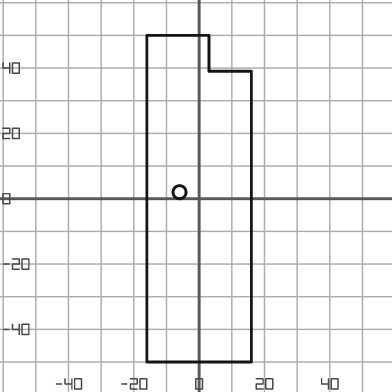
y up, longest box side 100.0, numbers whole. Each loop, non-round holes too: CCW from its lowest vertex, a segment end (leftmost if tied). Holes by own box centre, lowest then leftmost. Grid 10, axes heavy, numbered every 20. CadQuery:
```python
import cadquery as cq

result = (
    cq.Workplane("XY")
    .moveTo(-16.0, -50.0)
    .lineTo(16.0, -50.0)
    .lineTo(16.0, 39.0)
    .lineTo(3.0, 39.0)
    .lineTo(3.0, 50.0)
    .lineTo(-16.0, 50.0)
    .close()
    .moveTo(-6.0, 2.0)
    .circle(2.0)
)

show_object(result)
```